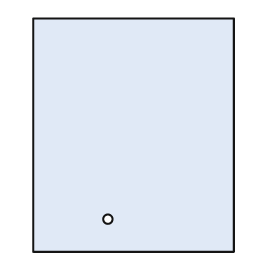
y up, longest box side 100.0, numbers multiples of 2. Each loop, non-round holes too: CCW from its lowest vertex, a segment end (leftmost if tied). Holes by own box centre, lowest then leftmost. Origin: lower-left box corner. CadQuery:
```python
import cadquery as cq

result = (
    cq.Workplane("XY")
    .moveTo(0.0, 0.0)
    .lineTo(86.0, 0.0)
    .lineTo(86.0, 100.0)
    .lineTo(0.0, 100.0)
    .close()
    .moveTo(32.0, 14.0)
    .circle(2.0)
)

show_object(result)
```